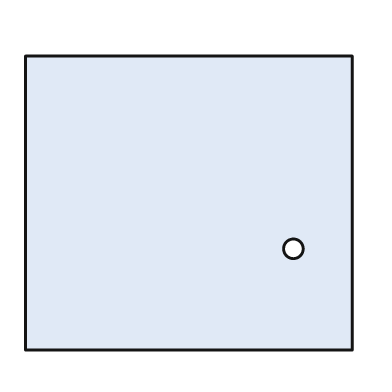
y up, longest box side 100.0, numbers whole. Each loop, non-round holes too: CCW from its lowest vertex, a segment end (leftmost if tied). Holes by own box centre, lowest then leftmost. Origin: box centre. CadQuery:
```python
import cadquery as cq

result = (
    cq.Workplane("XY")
    .moveTo(-50.0, -45.0)
    .lineTo(50.0, -45.0)
    .lineTo(50.0, 45.0)
    .lineTo(-50.0, 45.0)
    .close()
    .moveTo(32.0, -14.0)
    .circle(3.0)
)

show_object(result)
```